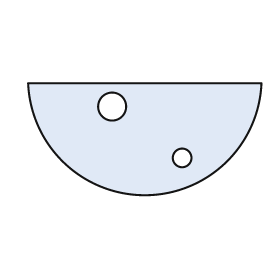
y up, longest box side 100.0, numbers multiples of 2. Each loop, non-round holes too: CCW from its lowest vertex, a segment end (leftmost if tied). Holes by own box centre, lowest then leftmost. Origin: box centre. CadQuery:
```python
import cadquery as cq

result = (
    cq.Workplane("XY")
    .moveTo(-50.0, 24.0)
    .threePointArc((0.0, -24.0), (50.0, 24.0))
    .close()
    .moveTo(16.0, -8.0)
    .circle(4.0)
    .moveTo(-14.0, 14.0)
    .circle(6.0)
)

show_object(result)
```